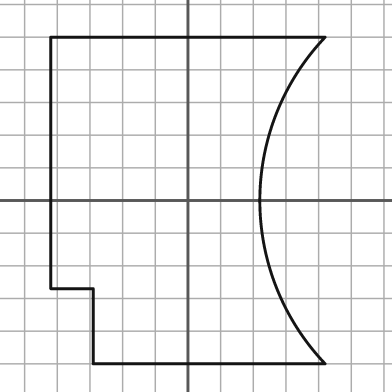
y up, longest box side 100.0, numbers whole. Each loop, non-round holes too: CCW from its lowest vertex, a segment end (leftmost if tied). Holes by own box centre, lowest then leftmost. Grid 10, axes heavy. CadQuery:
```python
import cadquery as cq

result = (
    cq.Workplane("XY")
    .moveTo(-29.0, -50.0)
    .lineTo(42.0, -50.0)
    .threePointArc((22.0, 0.0), (42.0, 50.0))
    .lineTo(-42.0, 50.0)
    .lineTo(-42.0, -27.0)
    .lineTo(-29.0, -27.0)
    .close()
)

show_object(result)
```